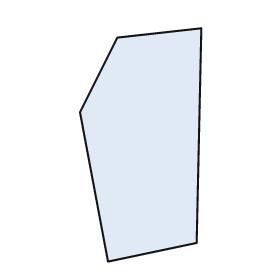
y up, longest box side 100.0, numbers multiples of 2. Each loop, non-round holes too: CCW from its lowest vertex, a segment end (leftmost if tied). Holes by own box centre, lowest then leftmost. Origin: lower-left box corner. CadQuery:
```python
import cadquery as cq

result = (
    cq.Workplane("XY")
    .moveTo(12.0, 0.0)
    .lineTo(50.0, 8.0)
    .lineTo(52.0, 100.0)
    .lineTo(16.0, 96.0)
    .lineTo(0.0, 64.0)
    .close()
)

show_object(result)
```